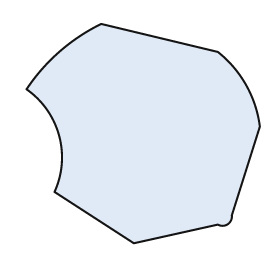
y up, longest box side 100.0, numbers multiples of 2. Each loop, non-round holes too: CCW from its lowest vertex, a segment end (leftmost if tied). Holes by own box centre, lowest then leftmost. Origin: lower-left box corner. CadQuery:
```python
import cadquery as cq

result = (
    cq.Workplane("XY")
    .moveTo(46.0, 0.0)
    .lineTo(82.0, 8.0)
    .threePointArc((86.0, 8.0), (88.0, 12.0))
    .lineTo(100.0, 50.0)
    .threePointArc((94.0, 68.0), (82.0, 82.0))
    .lineTo(32.0, 94.0)
    .threePointArc((14.0, 82.0), (0.0, 66.0))
    .threePointArc((14.0, 46.0), (12.0, 22.0))
    .close()
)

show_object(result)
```